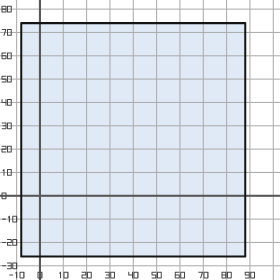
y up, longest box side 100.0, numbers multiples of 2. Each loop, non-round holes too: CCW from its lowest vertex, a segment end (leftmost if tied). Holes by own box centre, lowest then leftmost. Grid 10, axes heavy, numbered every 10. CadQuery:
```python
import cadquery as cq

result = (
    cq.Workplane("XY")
    .moveTo(-8.0, -26.0)
    .lineTo(88.0, -26.0)
    .lineTo(88.0, 74.0)
    .lineTo(-8.0, 74.0)
    .close()
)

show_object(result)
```